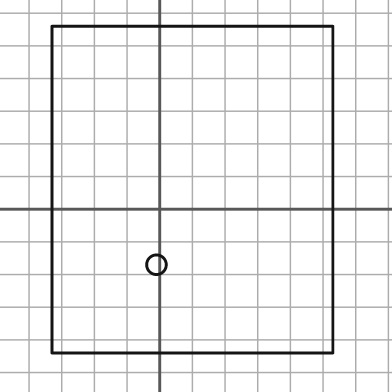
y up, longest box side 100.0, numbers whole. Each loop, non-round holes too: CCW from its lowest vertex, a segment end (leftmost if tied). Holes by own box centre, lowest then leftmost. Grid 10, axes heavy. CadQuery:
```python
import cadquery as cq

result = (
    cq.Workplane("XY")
    .moveTo(-33.0, -44.0)
    .lineTo(53.0, -44.0)
    .lineTo(53.0, 56.0)
    .lineTo(-33.0, 56.0)
    .close()
    .moveTo(-1.0, -17.0)
    .circle(3.0)
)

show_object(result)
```